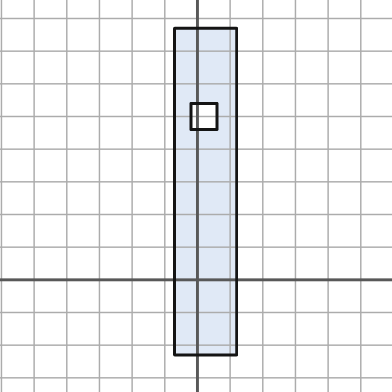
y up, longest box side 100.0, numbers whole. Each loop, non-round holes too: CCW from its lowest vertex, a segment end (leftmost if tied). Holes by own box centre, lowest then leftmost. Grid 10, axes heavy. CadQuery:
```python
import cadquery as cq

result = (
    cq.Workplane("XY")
    .moveTo(-7.0, -23.0)
    .lineTo(12.0, -23.0)
    .lineTo(12.0, 77.0)
    .lineTo(-7.0, 77.0)
    .close()
    .moveTo(-2.0, 46.0)
    .lineTo(6.0, 46.0)
    .lineTo(6.0, 54.0)
    .lineTo(-2.0, 54.0)
    .close()
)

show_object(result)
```